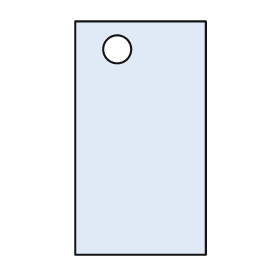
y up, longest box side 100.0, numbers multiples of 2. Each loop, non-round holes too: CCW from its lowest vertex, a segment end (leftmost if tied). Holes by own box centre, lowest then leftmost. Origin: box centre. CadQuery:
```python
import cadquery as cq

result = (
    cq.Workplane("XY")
    .moveTo(-28.0, -50.0)
    .lineTo(28.0, -50.0)
    .lineTo(28.0, 50.0)
    .lineTo(-28.0, 50.0)
    .close()
    .moveTo(-10.0, 38.0)
    .circle(6.0)
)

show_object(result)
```